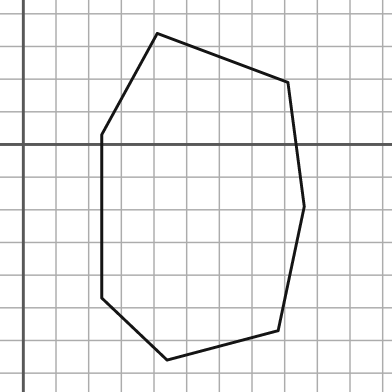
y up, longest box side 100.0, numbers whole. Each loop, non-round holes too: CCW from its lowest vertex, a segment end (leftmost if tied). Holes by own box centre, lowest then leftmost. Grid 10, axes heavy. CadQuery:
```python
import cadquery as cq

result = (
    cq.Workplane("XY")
    .moveTo(44.0, -66.0)
    .lineTo(78.0, -57.0)
    .lineTo(86.0, -19.0)
    .lineTo(81.0, 19.0)
    .lineTo(41.0, 34.0)
    .lineTo(24.0, 3.0)
    .lineTo(24.0, -47.0)
    .close()
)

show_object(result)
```